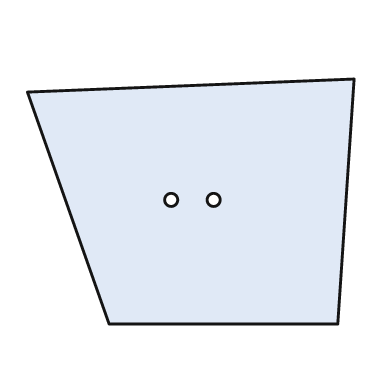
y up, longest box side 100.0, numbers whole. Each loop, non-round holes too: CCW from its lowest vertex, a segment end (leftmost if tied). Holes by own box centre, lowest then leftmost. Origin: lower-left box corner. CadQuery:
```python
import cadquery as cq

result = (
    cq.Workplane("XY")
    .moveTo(25.0, 0.0)
    .lineTo(95.0, 0.0)
    .lineTo(100.0, 75.0)
    .lineTo(0.0, 71.0)
    .close()
    .moveTo(44.0, 38.0)
    .circle(2.0)
    .moveTo(57.0, 38.0)
    .circle(2.0)
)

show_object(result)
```